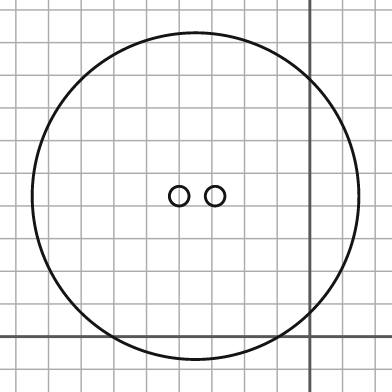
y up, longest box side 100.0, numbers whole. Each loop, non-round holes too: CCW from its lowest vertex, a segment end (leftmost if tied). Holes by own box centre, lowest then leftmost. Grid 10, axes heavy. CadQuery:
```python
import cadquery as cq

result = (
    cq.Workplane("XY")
    .moveTo(-35.0, 43.0)
    .circle(50.0)
    .moveTo(-40.0, 43.0)
    .circle(3.0)
    .moveTo(-29.0, 43.0)
    .circle(3.0)
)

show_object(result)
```